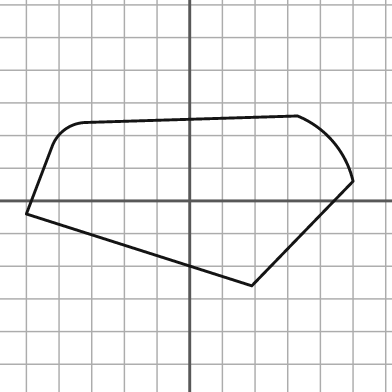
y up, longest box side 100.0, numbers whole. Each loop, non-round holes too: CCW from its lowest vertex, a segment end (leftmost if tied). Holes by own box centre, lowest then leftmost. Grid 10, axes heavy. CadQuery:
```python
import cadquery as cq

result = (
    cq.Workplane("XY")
    .moveTo(19.0, -26.0)
    .lineTo(50.0, 6.0)
    .threePointArc((44.0, 18.0), (33.0, 26.0))
    .lineTo(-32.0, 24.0)
    .threePointArc((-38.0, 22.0), (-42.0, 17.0))
    .lineTo(-50.0, -4.0)
    .close()
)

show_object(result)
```